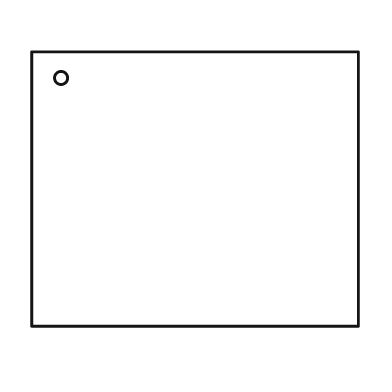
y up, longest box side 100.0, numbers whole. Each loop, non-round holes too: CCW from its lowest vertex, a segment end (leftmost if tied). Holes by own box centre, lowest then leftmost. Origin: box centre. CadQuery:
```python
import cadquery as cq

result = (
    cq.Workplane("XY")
    .moveTo(-50.0, -42.0)
    .lineTo(50.0, -42.0)
    .lineTo(50.0, 42.0)
    .lineTo(-50.0, 42.0)
    .close()
    .moveTo(-41.0, 34.0)
    .circle(2.0)
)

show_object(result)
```